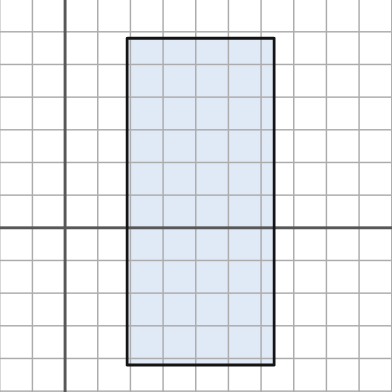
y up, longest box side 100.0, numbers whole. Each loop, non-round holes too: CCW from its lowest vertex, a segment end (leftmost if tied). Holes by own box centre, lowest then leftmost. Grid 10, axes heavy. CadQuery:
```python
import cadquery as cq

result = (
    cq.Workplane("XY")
    .moveTo(19.0, -42.0)
    .lineTo(64.0, -42.0)
    .lineTo(64.0, 58.0)
    .lineTo(19.0, 58.0)
    .close()
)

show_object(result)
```